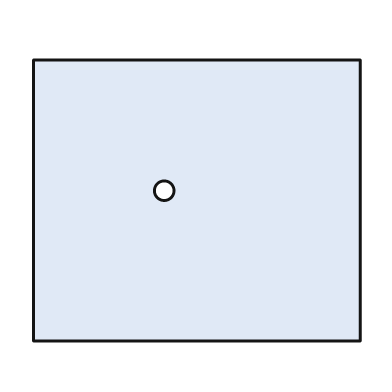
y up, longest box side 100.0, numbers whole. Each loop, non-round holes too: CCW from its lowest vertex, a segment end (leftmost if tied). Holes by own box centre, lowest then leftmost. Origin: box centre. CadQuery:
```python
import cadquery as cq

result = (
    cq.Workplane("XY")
    .moveTo(-50.0, -43.0)
    .lineTo(50.0, -43.0)
    .lineTo(50.0, 43.0)
    .lineTo(-50.0, 43.0)
    .close()
    .moveTo(-10.0, 3.0)
    .circle(3.0)
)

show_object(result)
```